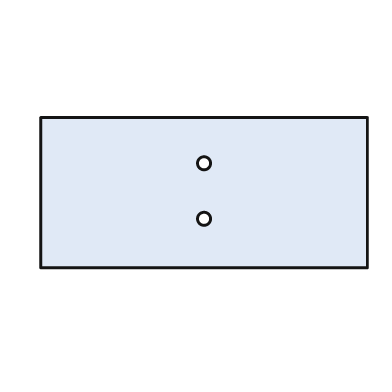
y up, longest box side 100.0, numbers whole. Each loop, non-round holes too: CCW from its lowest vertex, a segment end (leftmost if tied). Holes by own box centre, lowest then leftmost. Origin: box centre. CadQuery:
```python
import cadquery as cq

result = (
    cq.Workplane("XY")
    .moveTo(-50.0, -23.0)
    .lineTo(50.0, -23.0)
    .lineTo(50.0, 23.0)
    .lineTo(-50.0, 23.0)
    .close()
    .moveTo(0.0, -8.0)
    .circle(2.0)
    .moveTo(0.0, 9.0)
    .circle(2.0)
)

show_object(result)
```